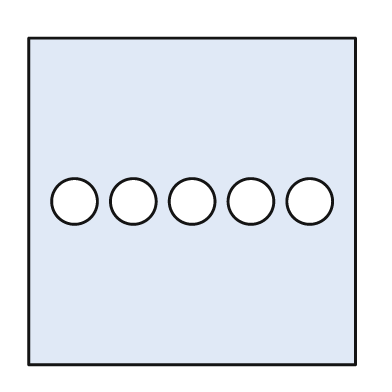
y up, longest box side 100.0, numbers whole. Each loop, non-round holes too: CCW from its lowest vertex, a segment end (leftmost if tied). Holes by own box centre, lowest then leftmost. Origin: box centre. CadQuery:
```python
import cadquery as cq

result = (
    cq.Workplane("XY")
    .moveTo(-50.0, -50.0)
    .lineTo(50.0, -50.0)
    .lineTo(50.0, 50.0)
    .lineTo(-50.0, 50.0)
    .close()
    .moveTo(-36.0, 0.0)
    .circle(7.0)
    .moveTo(-18.0, 0.0)
    .circle(7.0)
    .moveTo(0.0, 0.0)
    .circle(7.0)
    .moveTo(18.0, 0.0)
    .circle(7.0)
    .moveTo(36.0, 0.0)
    .circle(7.0)
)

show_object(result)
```